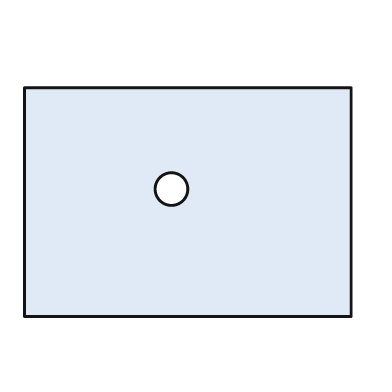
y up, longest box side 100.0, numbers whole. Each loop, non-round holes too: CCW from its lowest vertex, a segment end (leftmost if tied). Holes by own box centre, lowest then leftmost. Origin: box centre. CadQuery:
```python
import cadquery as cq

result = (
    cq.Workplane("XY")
    .moveTo(-50.0, -35.0)
    .lineTo(50.0, -35.0)
    .lineTo(50.0, 35.0)
    .lineTo(-50.0, 35.0)
    .close()
    .moveTo(-5.0, 4.0)
    .circle(5.0)
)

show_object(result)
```